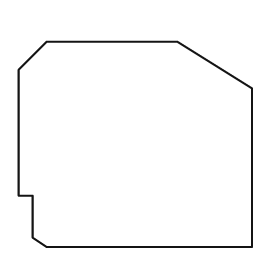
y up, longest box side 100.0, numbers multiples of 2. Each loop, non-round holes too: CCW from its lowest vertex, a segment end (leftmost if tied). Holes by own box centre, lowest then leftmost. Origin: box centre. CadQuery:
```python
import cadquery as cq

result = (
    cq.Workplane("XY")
    .moveTo(-38.0, -44.0)
    .lineTo(50.0, -44.0)
    .lineTo(50.0, 24.0)
    .lineTo(18.0, 44.0)
    .lineTo(-38.0, 44.0)
    .lineTo(-50.0, 32.0)
    .lineTo(-50.0, -22.0)
    .lineTo(-44.0, -22.0)
    .lineTo(-44.0, -40.0)
    .close()
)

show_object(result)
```